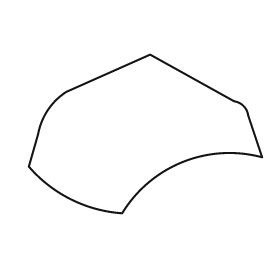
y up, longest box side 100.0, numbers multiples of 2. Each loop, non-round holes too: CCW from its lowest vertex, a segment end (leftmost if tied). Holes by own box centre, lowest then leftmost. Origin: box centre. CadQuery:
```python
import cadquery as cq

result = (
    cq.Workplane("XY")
    .moveTo(-10.0, -34.0)
    .threePointArc((16.0, -12.0), (50.0, -10.0))
    .lineTo(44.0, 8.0)
    .threePointArc((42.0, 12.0), (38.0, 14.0))
    .lineTo(2.0, 34.0)
    .lineTo(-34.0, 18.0)
    .threePointArc((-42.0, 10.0), (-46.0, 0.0))
    .lineTo(-50.0, -14.0)
    .threePointArc((-32.0, -28.0), (-10.0, -34.0))
    .close()
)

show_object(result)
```